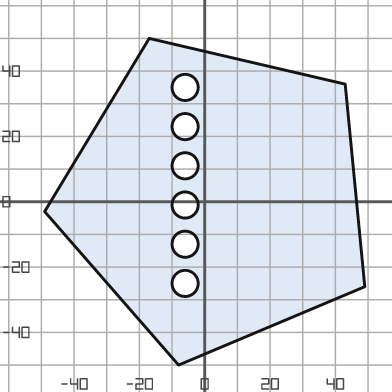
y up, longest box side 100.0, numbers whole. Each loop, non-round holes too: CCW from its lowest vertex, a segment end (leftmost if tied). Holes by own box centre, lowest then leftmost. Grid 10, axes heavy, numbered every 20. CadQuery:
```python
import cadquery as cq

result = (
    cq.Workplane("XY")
    .moveTo(-8.0, -50.0)
    .lineTo(49.0, -26.0)
    .lineTo(43.0, 36.0)
    .lineTo(-17.0, 50.0)
    .lineTo(-49.0, -3.0)
    .close()
    .moveTo(-6.0, -25.0)
    .circle(4.0)
    .moveTo(-6.0, -13.0)
    .circle(4.0)
    .moveTo(-6.0, -1.0)
    .circle(4.0)
    .moveTo(-6.0, 11.0)
    .circle(4.0)
    .moveTo(-6.0, 23.0)
    .circle(4.0)
    .moveTo(-6.0, 35.0)
    .circle(4.0)
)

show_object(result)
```